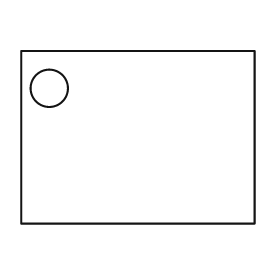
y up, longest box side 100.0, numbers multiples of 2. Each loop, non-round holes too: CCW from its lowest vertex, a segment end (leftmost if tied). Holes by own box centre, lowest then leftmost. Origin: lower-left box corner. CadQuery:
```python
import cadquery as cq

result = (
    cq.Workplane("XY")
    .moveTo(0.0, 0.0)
    .lineTo(100.0, 0.0)
    .lineTo(100.0, 74.0)
    .lineTo(0.0, 74.0)
    .close()
    .moveTo(12.0, 58.0)
    .circle(8.0)
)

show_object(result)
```